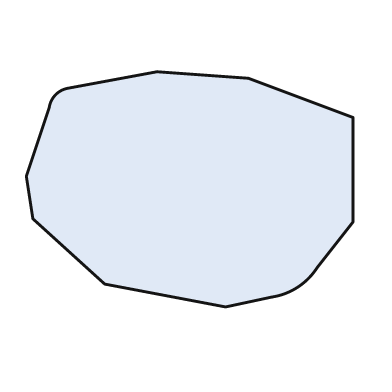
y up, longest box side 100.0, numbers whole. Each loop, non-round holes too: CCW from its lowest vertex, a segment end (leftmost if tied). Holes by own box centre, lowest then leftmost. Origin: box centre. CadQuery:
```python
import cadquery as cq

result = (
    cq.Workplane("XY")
    .moveTo(11.0, -36.0)
    .lineTo(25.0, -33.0)
    .threePointArc((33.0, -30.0), (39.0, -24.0))
    .lineTo(50.0, -10.0)
    .lineTo(50.0, 22.0)
    .lineTo(18.0, 34.0)
    .lineTo(-10.0, 36.0)
    .lineTo(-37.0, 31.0)
    .threePointArc((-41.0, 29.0), (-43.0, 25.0))
    .lineTo(-50.0, 4.0)
    .lineTo(-48.0, -9.0)
    .lineTo(-26.0, -29.0)
    .close()
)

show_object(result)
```